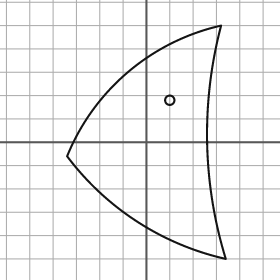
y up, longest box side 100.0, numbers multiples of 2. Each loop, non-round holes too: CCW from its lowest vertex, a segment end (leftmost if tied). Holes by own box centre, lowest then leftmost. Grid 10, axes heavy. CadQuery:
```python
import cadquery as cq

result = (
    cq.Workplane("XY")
    .moveTo(34.0, -50.0)
    .threePointArc((26.0, 0.0), (32.0, 50.0))
    .threePointArc((-8.0, 30.0), (-34.0, -6.0))
    .threePointArc((-4.0, -34.0), (34.0, -50.0))
    .close()
    .moveTo(10.0, 18.0)
    .circle(2.0)
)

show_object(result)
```